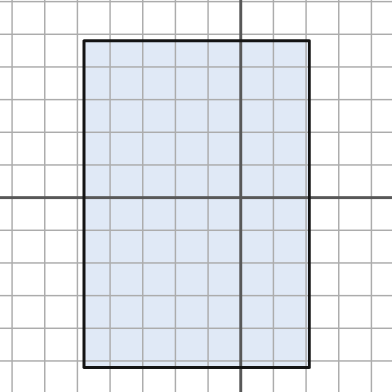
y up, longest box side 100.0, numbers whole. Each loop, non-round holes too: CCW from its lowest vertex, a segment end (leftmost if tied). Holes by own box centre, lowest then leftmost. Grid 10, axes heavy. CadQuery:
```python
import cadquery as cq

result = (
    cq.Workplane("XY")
    .moveTo(-48.0, -52.0)
    .lineTo(21.0, -52.0)
    .lineTo(21.0, 48.0)
    .lineTo(-48.0, 48.0)
    .close()
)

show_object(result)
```